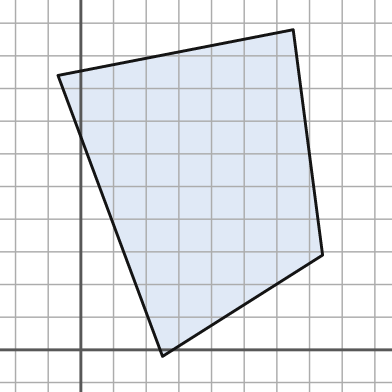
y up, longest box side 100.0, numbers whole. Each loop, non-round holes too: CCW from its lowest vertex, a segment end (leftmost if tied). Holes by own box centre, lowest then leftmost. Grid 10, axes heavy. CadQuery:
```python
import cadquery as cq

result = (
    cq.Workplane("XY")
    .moveTo(25.0, -2.0)
    .lineTo(74.0, 29.0)
    .lineTo(65.0, 98.0)
    .lineTo(-7.0, 84.0)
    .close()
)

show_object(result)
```